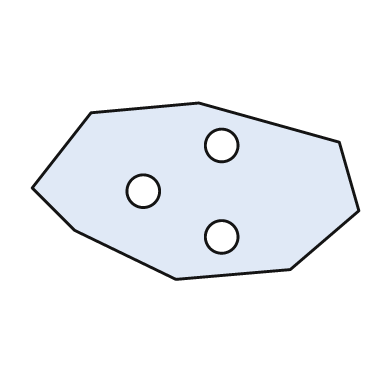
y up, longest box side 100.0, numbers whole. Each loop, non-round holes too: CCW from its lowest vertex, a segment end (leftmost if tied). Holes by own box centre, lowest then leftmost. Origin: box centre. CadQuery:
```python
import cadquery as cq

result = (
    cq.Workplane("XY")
    .moveTo(-6.0, -27.0)
    .lineTo(29.0, -24.0)
    .lineTo(50.0, -6.0)
    .lineTo(44.0, 15.0)
    .lineTo(1.0, 27.0)
    .lineTo(-32.0, 24.0)
    .lineTo(-50.0, 1.0)
    .lineTo(-37.0, -12.0)
    .close()
    .moveTo(8.0, -14.0)
    .circle(5.0)
    .moveTo(-16.0, 0.0)
    .circle(5.0)
    .moveTo(8.0, 14.0)
    .circle(5.0)
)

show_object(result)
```